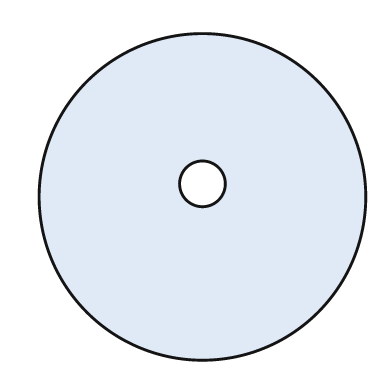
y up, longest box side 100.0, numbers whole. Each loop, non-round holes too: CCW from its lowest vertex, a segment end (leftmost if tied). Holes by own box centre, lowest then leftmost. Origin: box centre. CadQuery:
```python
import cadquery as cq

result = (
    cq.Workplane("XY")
    .moveTo(0.0, 0.0)
    .circle(50.0)
    .moveTo(0.0, 4.0)
    .circle(7.0)
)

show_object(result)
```